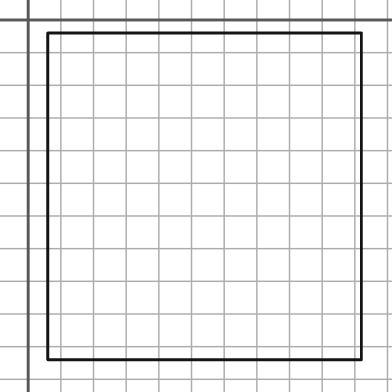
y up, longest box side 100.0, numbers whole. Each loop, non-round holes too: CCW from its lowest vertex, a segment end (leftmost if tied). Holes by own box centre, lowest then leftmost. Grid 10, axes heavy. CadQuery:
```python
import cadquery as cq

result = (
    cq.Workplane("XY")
    .moveTo(6.0, -104.0)
    .lineTo(102.0, -104.0)
    .lineTo(102.0, -4.0)
    .lineTo(6.0, -4.0)
    .close()
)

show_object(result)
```